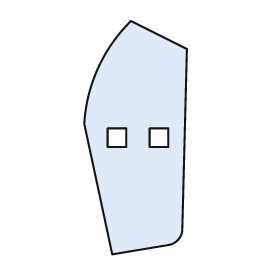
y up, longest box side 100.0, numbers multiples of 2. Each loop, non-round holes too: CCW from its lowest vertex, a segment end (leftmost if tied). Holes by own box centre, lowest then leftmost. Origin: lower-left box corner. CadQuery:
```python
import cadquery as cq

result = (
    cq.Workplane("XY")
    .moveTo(12.0, 0.0)
    .lineTo(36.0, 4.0)
    .threePointArc((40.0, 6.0), (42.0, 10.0))
    .lineTo(44.0, 88.0)
    .lineTo(20.0, 100.0)
    .threePointArc((6.0, 80.0), (0.0, 56.0))
    .close()
    .moveTo(10.0, 46.0)
    .lineTo(18.0, 46.0)
    .lineTo(18.0, 54.0)
    .lineTo(10.0, 54.0)
    .close()
    .moveTo(28.0, 46.0)
    .lineTo(36.0, 46.0)
    .lineTo(36.0, 54.0)
    .lineTo(28.0, 54.0)
    .close()
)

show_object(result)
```